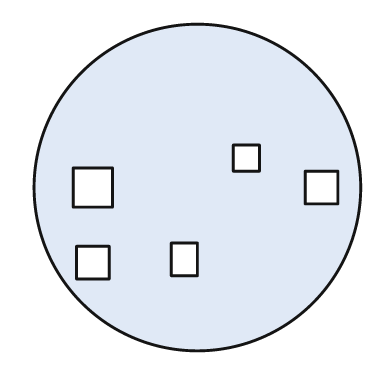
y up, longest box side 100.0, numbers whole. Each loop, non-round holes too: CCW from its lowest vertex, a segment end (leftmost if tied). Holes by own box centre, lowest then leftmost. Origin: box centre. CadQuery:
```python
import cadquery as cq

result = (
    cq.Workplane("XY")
    .moveTo(0.0, 0.0)
    .circle(50.0)
    .moveTo(-37.0, -28.0)
    .lineTo(-27.0, -28.0)
    .lineTo(-27.0, -18.0)
    .lineTo(-37.0, -18.0)
    .close()
    .moveTo(-8.0, -27.0)
    .lineTo(0.0, -27.0)
    .lineTo(0.0, -17.0)
    .lineTo(-8.0, -17.0)
    .close()
    .moveTo(-38.0, -6.0)
    .lineTo(-26.0, -6.0)
    .lineTo(-26.0, 6.0)
    .lineTo(-38.0, 6.0)
    .close()
    .moveTo(33.0, -5.0)
    .lineTo(43.0, -5.0)
    .lineTo(43.0, 5.0)
    .lineTo(33.0, 5.0)
    .close()
    .moveTo(11.0, 5.0)
    .lineTo(19.0, 5.0)
    .lineTo(19.0, 13.0)
    .lineTo(11.0, 13.0)
    .close()
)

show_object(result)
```